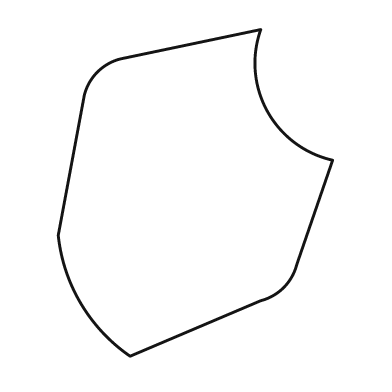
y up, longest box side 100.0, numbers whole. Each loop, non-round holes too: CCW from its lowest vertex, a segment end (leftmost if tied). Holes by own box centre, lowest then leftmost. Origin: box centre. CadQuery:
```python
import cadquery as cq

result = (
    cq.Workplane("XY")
    .moveTo(-20.0, -50.0)
    .lineTo(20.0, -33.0)
    .threePointArc((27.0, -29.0), (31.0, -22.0))
    .lineTo(42.0, 10.0)
    .threePointArc((22.0, 25.0), (20.0, 50.0))
    .lineTo(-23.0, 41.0)
    .threePointArc((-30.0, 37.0), (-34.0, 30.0))
    .lineTo(-42.0, -13.0)
    .threePointArc((-35.0, -34.0), (-20.0, -50.0))
    .close()
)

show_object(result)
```